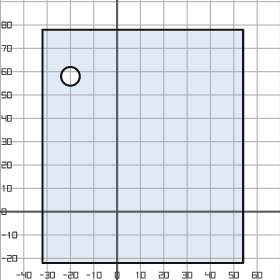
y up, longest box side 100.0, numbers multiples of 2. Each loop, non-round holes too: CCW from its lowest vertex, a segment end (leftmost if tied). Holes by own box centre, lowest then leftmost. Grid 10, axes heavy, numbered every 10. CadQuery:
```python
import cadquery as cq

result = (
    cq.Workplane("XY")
    .moveTo(-32.0, -22.0)
    .lineTo(54.0, -22.0)
    .lineTo(54.0, 78.0)
    .lineTo(-32.0, 78.0)
    .close()
    .moveTo(-20.0, 58.0)
    .circle(4.0)
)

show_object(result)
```